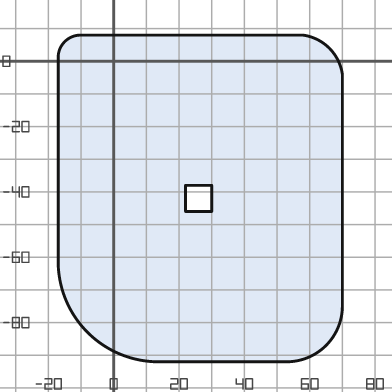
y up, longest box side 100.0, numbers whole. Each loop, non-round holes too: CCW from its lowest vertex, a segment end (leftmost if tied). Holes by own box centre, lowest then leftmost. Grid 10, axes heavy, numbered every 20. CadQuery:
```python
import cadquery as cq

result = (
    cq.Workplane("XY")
    .moveTo(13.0, -92.0)
    .lineTo(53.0, -92.0)
    .threePointArc((65.0, -87.0), (70.0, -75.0))
    .lineTo(70.0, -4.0)
    .threePointArc((66.0, 4.0), (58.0, 8.0))
    .lineTo(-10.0, 8.0)
    .threePointArc((-15.0, 6.0), (-17.0, 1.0))
    .lineTo(-17.0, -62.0)
    .threePointArc((-8.0, -83.0), (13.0, -92.0))
    .close()
    .moveTo(22.0, -46.0)
    .lineTo(30.0, -46.0)
    .lineTo(30.0, -38.0)
    .lineTo(22.0, -38.0)
    .close()
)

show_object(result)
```